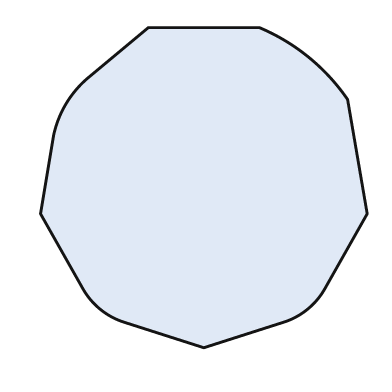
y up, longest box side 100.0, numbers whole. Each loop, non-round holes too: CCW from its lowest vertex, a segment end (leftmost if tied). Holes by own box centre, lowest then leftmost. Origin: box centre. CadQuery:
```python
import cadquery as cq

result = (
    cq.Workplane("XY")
    .moveTo(0.0, -49.0)
    .lineTo(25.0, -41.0)
    .threePointArc((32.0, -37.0), (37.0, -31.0))
    .lineTo(50.0, -8.0)
    .lineTo(44.0, 27.0)
    .threePointArc((32.0, 40.0), (17.0, 49.0))
    .lineTo(-17.0, 49.0)
    .lineTo(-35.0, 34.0)
    .threePointArc((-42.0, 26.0), (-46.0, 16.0))
    .lineTo(-50.0, -8.0)
    .lineTo(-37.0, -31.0)
    .threePointArc((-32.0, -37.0), (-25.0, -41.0))
    .close()
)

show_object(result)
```